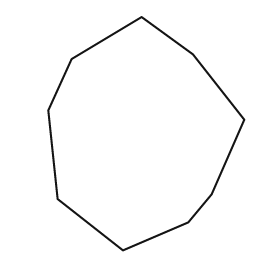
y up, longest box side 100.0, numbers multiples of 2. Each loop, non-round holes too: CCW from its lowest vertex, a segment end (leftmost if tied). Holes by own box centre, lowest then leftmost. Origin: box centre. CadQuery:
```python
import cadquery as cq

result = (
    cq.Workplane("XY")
    .moveTo(-10.0, -50.0)
    .lineTo(18.0, -38.0)
    .lineTo(28.0, -26.0)
    .lineTo(42.0, 6.0)
    .lineTo(20.0, 34.0)
    .lineTo(-2.0, 50.0)
    .lineTo(-32.0, 32.0)
    .lineTo(-42.0, 10.0)
    .lineTo(-38.0, -28.0)
    .close()
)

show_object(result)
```